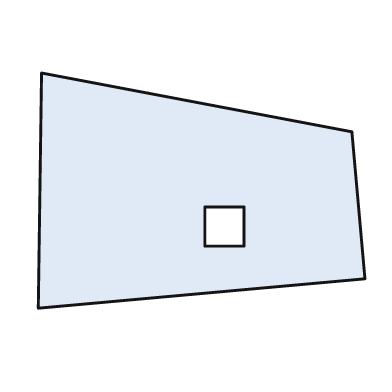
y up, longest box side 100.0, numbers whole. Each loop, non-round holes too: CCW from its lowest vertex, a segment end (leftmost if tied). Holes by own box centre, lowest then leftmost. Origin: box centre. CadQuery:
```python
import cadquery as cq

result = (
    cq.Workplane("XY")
    .moveTo(-50.0, -36.0)
    .lineTo(50.0, -27.0)
    .lineTo(46.0, 18.0)
    .lineTo(-49.0, 36.0)
    .close()
    .moveTo(1.0, -17.0)
    .lineTo(13.0, -17.0)
    .lineTo(13.0, -5.0)
    .lineTo(1.0, -5.0)
    .close()
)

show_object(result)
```